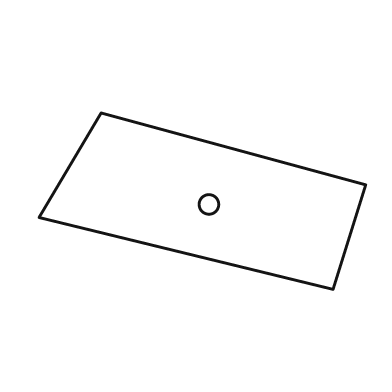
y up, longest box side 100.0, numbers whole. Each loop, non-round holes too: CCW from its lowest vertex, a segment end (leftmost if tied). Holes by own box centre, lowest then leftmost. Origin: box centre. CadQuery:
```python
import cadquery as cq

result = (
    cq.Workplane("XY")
    .moveTo(40.0, -27.0)
    .lineTo(50.0, 5.0)
    .lineTo(-31.0, 27.0)
    .lineTo(-50.0, -5.0)
    .close()
    .moveTo(2.0, -1.0)
    .circle(3.0)
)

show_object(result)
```